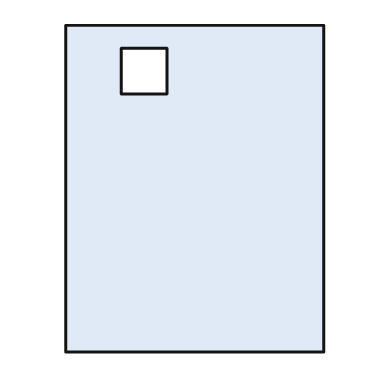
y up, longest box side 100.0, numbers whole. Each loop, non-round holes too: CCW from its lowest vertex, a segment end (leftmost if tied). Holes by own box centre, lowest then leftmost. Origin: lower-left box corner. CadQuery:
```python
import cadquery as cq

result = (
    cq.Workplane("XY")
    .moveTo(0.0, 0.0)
    .lineTo(79.0, 0.0)
    .lineTo(79.0, 100.0)
    .lineTo(0.0, 100.0)
    .close()
    .moveTo(17.0, 79.0)
    .lineTo(31.0, 79.0)
    .lineTo(31.0, 93.0)
    .lineTo(17.0, 93.0)
    .close()
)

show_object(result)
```